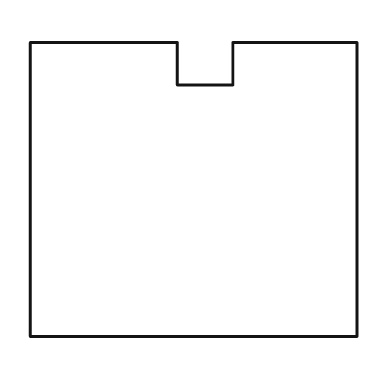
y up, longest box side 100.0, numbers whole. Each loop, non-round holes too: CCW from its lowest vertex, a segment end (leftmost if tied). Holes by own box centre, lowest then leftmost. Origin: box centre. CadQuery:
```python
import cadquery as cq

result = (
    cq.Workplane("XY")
    .moveTo(-50.0, -45.0)
    .lineTo(50.0, -45.0)
    .lineTo(50.0, 45.0)
    .lineTo(12.0, 45.0)
    .lineTo(12.0, 32.0)
    .lineTo(-5.0, 32.0)
    .lineTo(-5.0, 45.0)
    .lineTo(-50.0, 45.0)
    .close()
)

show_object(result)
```